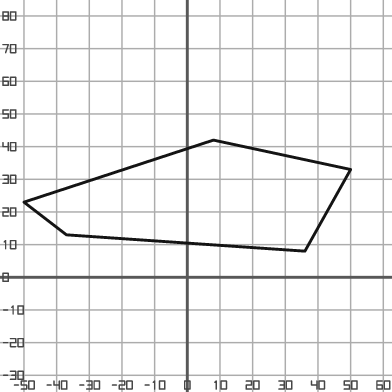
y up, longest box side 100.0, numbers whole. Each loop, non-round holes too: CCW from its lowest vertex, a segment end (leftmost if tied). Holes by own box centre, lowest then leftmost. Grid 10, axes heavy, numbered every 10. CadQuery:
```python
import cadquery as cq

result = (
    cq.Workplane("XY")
    .moveTo(36.0, 8.0)
    .lineTo(50.0, 33.0)
    .lineTo(8.0, 42.0)
    .lineTo(-50.0, 23.0)
    .lineTo(-37.0, 13.0)
    .close()
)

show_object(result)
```